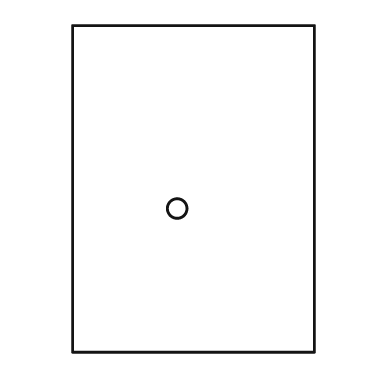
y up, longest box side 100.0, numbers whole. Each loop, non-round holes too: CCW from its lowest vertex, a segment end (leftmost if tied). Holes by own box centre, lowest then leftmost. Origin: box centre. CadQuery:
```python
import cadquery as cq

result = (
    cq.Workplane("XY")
    .moveTo(-37.0, -50.0)
    .lineTo(37.0, -50.0)
    .lineTo(37.0, 50.0)
    .lineTo(-37.0, 50.0)
    .close()
    .moveTo(-5.0, -6.0)
    .circle(3.0)
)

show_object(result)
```